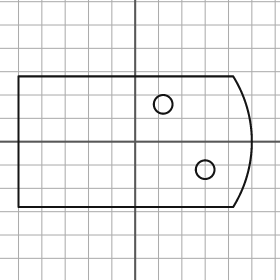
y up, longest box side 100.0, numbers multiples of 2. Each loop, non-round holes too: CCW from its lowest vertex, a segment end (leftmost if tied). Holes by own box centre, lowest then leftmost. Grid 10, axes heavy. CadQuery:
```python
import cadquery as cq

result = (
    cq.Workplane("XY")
    .moveTo(-50.0, -28.0)
    .lineTo(42.0, -28.0)
    .threePointArc((50.0, 0.0), (42.0, 28.0))
    .lineTo(-50.0, 28.0)
    .close()
    .moveTo(30.0, -12.0)
    .circle(4.0)
    .moveTo(12.0, 16.0)
    .circle(4.0)
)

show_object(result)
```